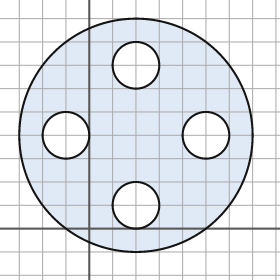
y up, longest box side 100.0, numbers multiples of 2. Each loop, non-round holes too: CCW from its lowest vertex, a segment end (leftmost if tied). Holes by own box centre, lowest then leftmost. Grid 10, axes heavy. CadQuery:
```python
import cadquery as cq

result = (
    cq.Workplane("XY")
    .moveTo(20.0, 40.0)
    .circle(50.0)
    .moveTo(20.0, 10.0)
    .circle(10.0)
    .moveTo(-10.0, 40.0)
    .circle(10.0)
    .moveTo(50.0, 40.0)
    .circle(10.0)
    .moveTo(20.0, 70.0)
    .circle(10.0)
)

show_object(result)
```